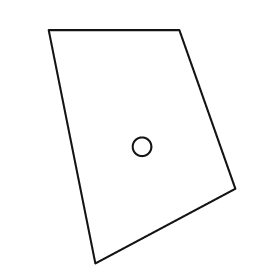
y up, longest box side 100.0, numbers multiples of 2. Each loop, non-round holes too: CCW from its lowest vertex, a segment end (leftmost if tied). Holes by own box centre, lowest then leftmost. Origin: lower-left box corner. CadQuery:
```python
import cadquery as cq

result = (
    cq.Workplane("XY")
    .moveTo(20.0, 0.0)
    .lineTo(80.0, 32.0)
    .lineTo(56.0, 100.0)
    .lineTo(0.0, 100.0)
    .close()
    .moveTo(40.0, 50.0)
    .circle(4.0)
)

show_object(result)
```